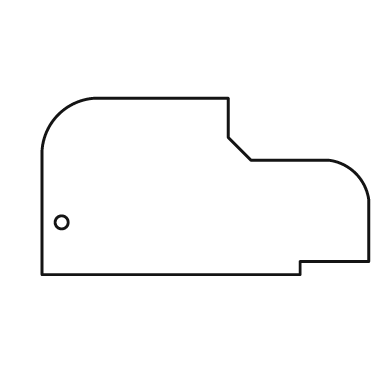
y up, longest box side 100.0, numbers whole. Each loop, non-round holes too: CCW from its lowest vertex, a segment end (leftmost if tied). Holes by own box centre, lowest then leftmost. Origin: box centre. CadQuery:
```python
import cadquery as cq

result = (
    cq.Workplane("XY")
    .moveTo(-50.0, -27.0)
    .lineTo(29.0, -27.0)
    .lineTo(29.0, -23.0)
    .lineTo(50.0, -23.0)
    .lineTo(50.0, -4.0)
    .threePointArc((46.0, 4.0), (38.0, 8.0))
    .lineTo(14.0, 8.0)
    .lineTo(7.0, 15.0)
    .lineTo(7.0, 27.0)
    .lineTo(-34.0, 27.0)
    .threePointArc((-45.0, 22.0), (-50.0, 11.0))
    .close()
    .moveTo(-44.0, -11.0)
    .circle(2.0)
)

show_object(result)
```